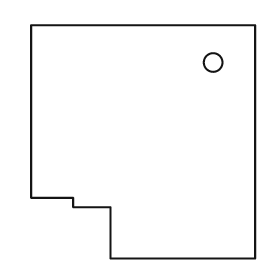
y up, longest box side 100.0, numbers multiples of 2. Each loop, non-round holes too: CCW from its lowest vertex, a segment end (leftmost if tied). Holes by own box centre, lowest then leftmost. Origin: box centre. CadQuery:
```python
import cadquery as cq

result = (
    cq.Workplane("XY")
    .moveTo(-14.0, -50.0)
    .lineTo(48.0, -50.0)
    .lineTo(48.0, 50.0)
    .lineTo(-48.0, 50.0)
    .lineTo(-48.0, -24.0)
    .lineTo(-30.0, -24.0)
    .lineTo(-30.0, -28.0)
    .lineTo(-14.0, -28.0)
    .close()
    .moveTo(30.0, 34.0)
    .circle(4.0)
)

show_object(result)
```